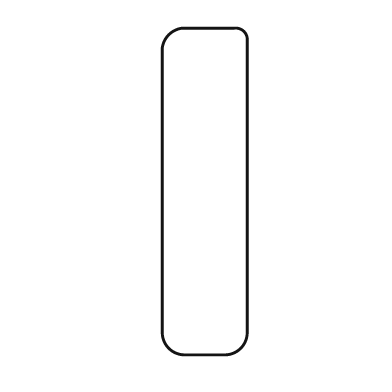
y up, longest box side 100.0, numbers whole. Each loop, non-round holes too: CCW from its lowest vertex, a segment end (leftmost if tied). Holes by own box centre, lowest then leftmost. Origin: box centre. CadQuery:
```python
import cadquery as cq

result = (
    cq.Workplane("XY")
    .moveTo(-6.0, -50.0)
    .lineTo(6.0, -50.0)
    .threePointArc((11.0, -48.0), (13.0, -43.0))
    .lineTo(13.0, 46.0)
    .threePointArc((12.0, 49.0), (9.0, 50.0))
    .lineTo(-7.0, 50.0)
    .threePointArc((-11.0, 48.0), (-13.0, 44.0))
    .lineTo(-13.0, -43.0)
    .threePointArc((-11.0, -48.0), (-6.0, -50.0))
    .close()
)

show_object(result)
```